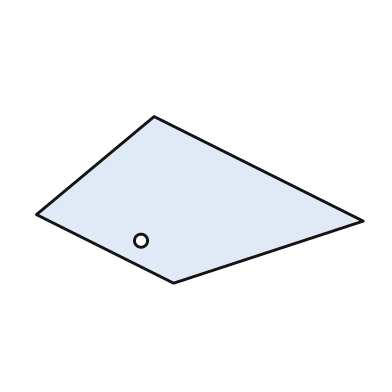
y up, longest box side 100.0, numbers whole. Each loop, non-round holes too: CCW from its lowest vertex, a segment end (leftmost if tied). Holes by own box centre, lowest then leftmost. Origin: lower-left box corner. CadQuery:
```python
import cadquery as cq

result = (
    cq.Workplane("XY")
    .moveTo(42.0, 0.0)
    .lineTo(100.0, 19.0)
    .lineTo(36.0, 51.0)
    .lineTo(0.0, 21.0)
    .close()
    .moveTo(32.0, 13.0)
    .circle(2.0)
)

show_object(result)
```